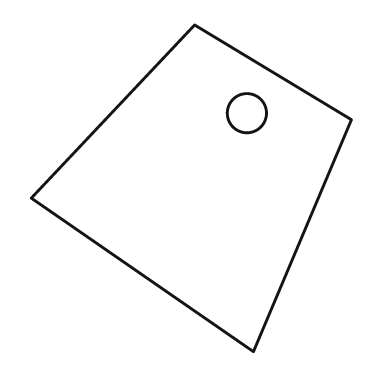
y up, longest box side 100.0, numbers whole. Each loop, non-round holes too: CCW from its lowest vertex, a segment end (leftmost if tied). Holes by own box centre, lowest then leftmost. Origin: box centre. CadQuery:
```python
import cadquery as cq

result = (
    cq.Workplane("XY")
    .moveTo(19.0, -50.0)
    .lineTo(49.0, 21.0)
    .lineTo(1.0, 50.0)
    .lineTo(-49.0, -3.0)
    .close()
    .moveTo(17.0, 23.0)
    .circle(6.0)
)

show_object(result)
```